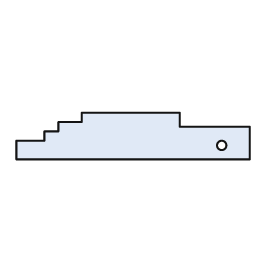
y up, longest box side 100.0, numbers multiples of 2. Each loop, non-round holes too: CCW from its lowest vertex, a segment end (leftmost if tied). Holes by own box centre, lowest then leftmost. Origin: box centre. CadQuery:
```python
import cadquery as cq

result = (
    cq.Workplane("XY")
    .moveTo(-50.0, -10.0)
    .lineTo(50.0, -10.0)
    .lineTo(50.0, 4.0)
    .lineTo(20.0, 4.0)
    .lineTo(20.0, 10.0)
    .lineTo(-22.0, 10.0)
    .lineTo(-22.0, 6.0)
    .lineTo(-32.0, 6.0)
    .lineTo(-32.0, 2.0)
    .lineTo(-38.0, 2.0)
    .lineTo(-38.0, -2.0)
    .lineTo(-50.0, -2.0)
    .close()
    .moveTo(38.0, -4.0)
    .circle(2.0)
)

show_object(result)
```